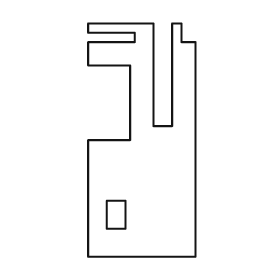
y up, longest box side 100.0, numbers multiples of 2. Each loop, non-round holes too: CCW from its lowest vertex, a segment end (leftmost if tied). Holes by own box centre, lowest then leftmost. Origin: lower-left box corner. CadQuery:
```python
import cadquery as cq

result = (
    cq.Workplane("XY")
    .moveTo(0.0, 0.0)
    .lineTo(46.0, 0.0)
    .lineTo(46.0, 92.0)
    .lineTo(40.0, 92.0)
    .lineTo(40.0, 100.0)
    .lineTo(36.0, 100.0)
    .lineTo(36.0, 56.0)
    .lineTo(28.0, 56.0)
    .lineTo(28.0, 100.0)
    .lineTo(0.0, 100.0)
    .lineTo(0.0, 96.0)
    .lineTo(20.0, 96.0)
    .lineTo(20.0, 92.0)
    .lineTo(0.0, 92.0)
    .lineTo(0.0, 82.0)
    .lineTo(18.0, 82.0)
    .lineTo(18.0, 50.0)
    .lineTo(0.0, 50.0)
    .close()
    .moveTo(8.0, 12.0)
    .lineTo(16.0, 12.0)
    .lineTo(16.0, 24.0)
    .lineTo(8.0, 24.0)
    .close()
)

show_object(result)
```